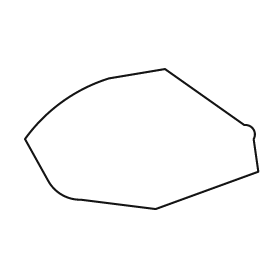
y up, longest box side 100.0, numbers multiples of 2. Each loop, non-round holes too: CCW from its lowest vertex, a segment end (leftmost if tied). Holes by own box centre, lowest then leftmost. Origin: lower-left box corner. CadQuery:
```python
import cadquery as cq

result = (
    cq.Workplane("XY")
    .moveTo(56.0, 0.0)
    .lineTo(100.0, 16.0)
    .lineTo(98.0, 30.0)
    .threePointArc((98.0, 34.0), (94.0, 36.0))
    .lineTo(60.0, 60.0)
    .lineTo(36.0, 56.0)
    .threePointArc((16.0, 46.0), (0.0, 30.0))
    .lineTo(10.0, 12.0)
    .threePointArc((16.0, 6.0), (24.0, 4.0))
    .close()
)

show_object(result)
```